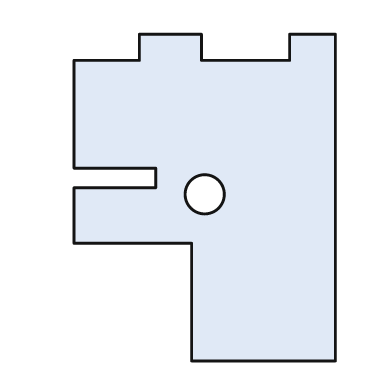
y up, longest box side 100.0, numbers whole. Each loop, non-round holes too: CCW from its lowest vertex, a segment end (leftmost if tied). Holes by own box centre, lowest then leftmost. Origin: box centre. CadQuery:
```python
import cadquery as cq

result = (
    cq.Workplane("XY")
    .moveTo(-4.0, -50.0)
    .lineTo(40.0, -50.0)
    .lineTo(40.0, 50.0)
    .lineTo(26.0, 50.0)
    .lineTo(26.0, 42.0)
    .lineTo(-1.0, 42.0)
    .lineTo(-1.0, 50.0)
    .lineTo(-20.0, 50.0)
    .lineTo(-20.0, 42.0)
    .lineTo(-40.0, 42.0)
    .lineTo(-40.0, 9.0)
    .lineTo(-15.0, 9.0)
    .lineTo(-15.0, 3.0)
    .lineTo(-40.0, 3.0)
    .lineTo(-40.0, -14.0)
    .lineTo(-4.0, -14.0)
    .close()
    .moveTo(0.0, 1.0)
    .circle(6.0)
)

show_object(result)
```